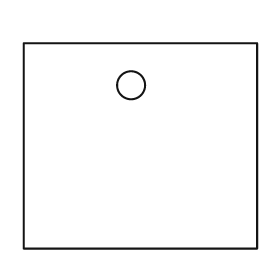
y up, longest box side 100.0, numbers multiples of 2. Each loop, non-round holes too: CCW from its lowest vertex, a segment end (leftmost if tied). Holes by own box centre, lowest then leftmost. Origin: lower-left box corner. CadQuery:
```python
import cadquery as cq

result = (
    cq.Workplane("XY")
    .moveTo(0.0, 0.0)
    .lineTo(100.0, 0.0)
    .lineTo(100.0, 88.0)
    .lineTo(0.0, 88.0)
    .close()
    .moveTo(46.0, 70.0)
    .circle(6.0)
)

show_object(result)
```